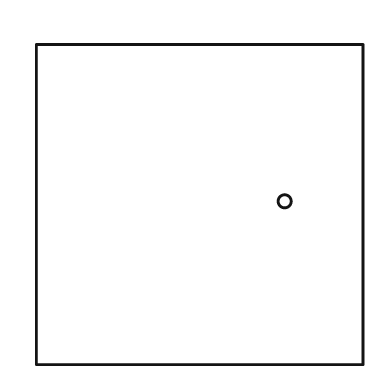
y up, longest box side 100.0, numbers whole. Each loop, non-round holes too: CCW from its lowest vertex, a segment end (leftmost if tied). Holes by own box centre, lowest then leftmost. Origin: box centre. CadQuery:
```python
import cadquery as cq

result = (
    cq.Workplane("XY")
    .moveTo(-50.0, -49.0)
    .lineTo(50.0, -49.0)
    .lineTo(50.0, 49.0)
    .lineTo(-50.0, 49.0)
    .close()
    .moveTo(26.0, 1.0)
    .circle(2.0)
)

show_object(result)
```